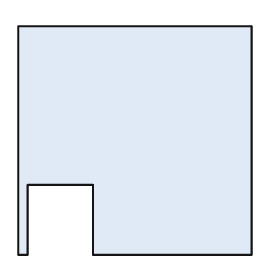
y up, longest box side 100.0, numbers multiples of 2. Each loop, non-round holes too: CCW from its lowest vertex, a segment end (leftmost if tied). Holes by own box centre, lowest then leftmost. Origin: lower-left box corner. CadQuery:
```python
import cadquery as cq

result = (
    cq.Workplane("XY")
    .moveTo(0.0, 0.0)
    .lineTo(4.0, 0.0)
    .lineTo(4.0, 30.0)
    .lineTo(32.0, 30.0)
    .lineTo(32.0, 0.0)
    .lineTo(100.0, 0.0)
    .lineTo(100.0, 98.0)
    .lineTo(0.0, 98.0)
    .close()
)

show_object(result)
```